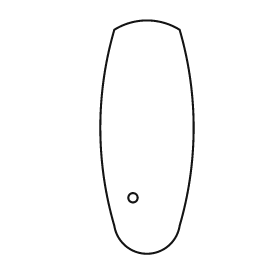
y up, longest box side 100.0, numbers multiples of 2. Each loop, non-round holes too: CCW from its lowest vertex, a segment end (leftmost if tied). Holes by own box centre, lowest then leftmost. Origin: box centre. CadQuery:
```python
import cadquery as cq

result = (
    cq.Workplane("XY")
    .moveTo(-14.0, -38.0)
    .threePointArc((0.0, -50.0), (14.0, -38.0))
    .threePointArc((20.0, 4.0), (14.0, 46.0))
    .threePointArc((0.0, 50.0), (-14.0, 46.0))
    .threePointArc((-20.0, 4.0), (-14.0, -38.0))
    .close()
    .moveTo(-6.0, -26.0)
    .circle(2.0)
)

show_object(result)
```